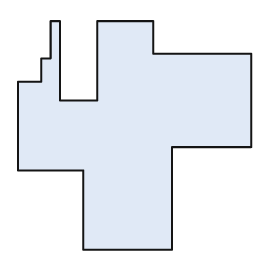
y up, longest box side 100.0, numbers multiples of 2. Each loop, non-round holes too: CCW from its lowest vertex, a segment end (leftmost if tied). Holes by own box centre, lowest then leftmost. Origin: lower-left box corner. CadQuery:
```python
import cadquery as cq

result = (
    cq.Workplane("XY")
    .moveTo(28.0, 0.0)
    .lineTo(66.0, 0.0)
    .lineTo(66.0, 44.0)
    .lineTo(100.0, 44.0)
    .lineTo(100.0, 84.0)
    .lineTo(58.0, 84.0)
    .lineTo(58.0, 98.0)
    .lineTo(34.0, 98.0)
    .lineTo(34.0, 64.0)
    .lineTo(18.0, 64.0)
    .lineTo(18.0, 98.0)
    .lineTo(14.0, 98.0)
    .lineTo(14.0, 82.0)
    .lineTo(10.0, 82.0)
    .lineTo(10.0, 72.0)
    .lineTo(0.0, 72.0)
    .lineTo(0.0, 34.0)
    .lineTo(28.0, 34.0)
    .close()
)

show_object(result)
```